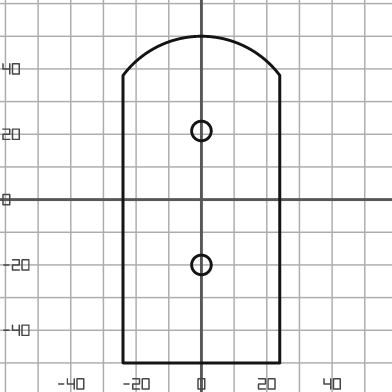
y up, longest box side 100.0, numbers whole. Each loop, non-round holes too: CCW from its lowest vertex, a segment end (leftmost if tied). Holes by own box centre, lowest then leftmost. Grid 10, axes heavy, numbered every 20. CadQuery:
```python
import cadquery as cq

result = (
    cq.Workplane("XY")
    .moveTo(-24.0, -50.0)
    .lineTo(24.0, -50.0)
    .lineTo(24.0, 38.0)
    .threePointArc((0.0, 50.0), (-24.0, 38.0))
    .close()
    .moveTo(0.0, -20.0)
    .circle(3.0)
    .moveTo(0.0, 21.0)
    .circle(3.0)
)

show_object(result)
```